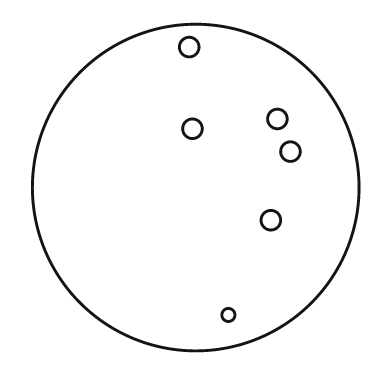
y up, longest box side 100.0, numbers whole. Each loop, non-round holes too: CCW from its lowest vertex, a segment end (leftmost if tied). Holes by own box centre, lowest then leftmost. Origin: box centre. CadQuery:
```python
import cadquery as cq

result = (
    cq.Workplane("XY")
    .moveTo(0.0, 0.0)
    .circle(50.0)
    .moveTo(10.0, -39.0)
    .circle(2.0)
    .moveTo(23.0, -10.0)
    .circle(3.0)
    .moveTo(29.0, 11.0)
    .circle(3.0)
    .moveTo(-1.0, 18.0)
    .circle(3.0)
    .moveTo(25.0, 21.0)
    .circle(3.0)
    .moveTo(-2.0, 43.0)
    .circle(3.0)
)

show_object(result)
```